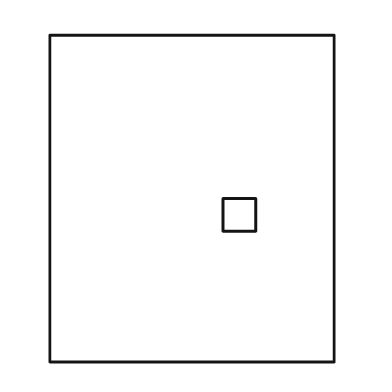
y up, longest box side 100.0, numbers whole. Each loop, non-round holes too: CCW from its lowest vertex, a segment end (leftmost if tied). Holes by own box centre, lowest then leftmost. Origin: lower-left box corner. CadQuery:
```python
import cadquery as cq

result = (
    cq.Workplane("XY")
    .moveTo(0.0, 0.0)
    .lineTo(87.0, 0.0)
    .lineTo(87.0, 100.0)
    .lineTo(0.0, 100.0)
    .close()
    .moveTo(53.0, 40.0)
    .lineTo(63.0, 40.0)
    .lineTo(63.0, 50.0)
    .lineTo(53.0, 50.0)
    .close()
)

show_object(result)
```